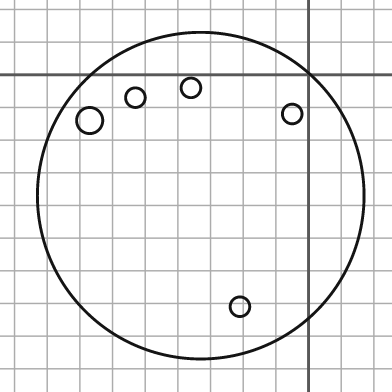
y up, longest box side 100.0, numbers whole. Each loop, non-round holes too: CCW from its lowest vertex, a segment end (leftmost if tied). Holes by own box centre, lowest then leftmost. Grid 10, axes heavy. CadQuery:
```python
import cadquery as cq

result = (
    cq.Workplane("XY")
    .moveTo(-33.0, -37.0)
    .circle(50.0)
    .moveTo(-21.0, -71.0)
    .circle(3.0)
    .moveTo(-67.0, -14.0)
    .circle(4.0)
    .moveTo(-5.0, -12.0)
    .circle(3.0)
    .moveTo(-53.0, -7.0)
    .circle(3.0)
    .moveTo(-36.0, -4.0)
    .circle(3.0)
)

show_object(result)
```